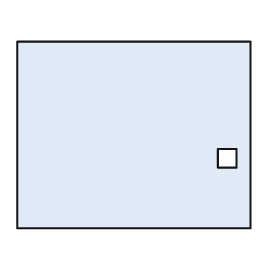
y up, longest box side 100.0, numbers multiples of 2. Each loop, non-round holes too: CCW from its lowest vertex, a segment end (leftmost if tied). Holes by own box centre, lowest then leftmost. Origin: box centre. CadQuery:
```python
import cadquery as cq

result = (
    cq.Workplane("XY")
    .moveTo(-50.0, -40.0)
    .lineTo(50.0, -40.0)
    .lineTo(50.0, 40.0)
    .lineTo(-50.0, 40.0)
    .close()
    .moveTo(36.0, -14.0)
    .lineTo(44.0, -14.0)
    .lineTo(44.0, -6.0)
    .lineTo(36.0, -6.0)
    .close()
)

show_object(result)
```